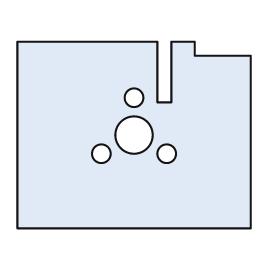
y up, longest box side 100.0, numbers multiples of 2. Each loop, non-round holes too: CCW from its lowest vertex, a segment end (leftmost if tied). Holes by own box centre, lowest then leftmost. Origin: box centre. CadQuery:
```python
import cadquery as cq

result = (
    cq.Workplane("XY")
    .moveTo(-50.0, -40.0)
    .lineTo(50.0, -40.0)
    .lineTo(50.0, 34.0)
    .lineTo(26.0, 34.0)
    .lineTo(26.0, 40.0)
    .lineTo(16.0, 40.0)
    .lineTo(16.0, 14.0)
    .lineTo(10.0, 14.0)
    .lineTo(10.0, 40.0)
    .lineTo(-50.0, 40.0)
    .close()
    .moveTo(-14.0, -8.0)
    .circle(4.0)
    .moveTo(14.0, -8.0)
    .circle(4.0)
    .moveTo(0.0, 0.0)
    .circle(8.0)
    .moveTo(0.0, 16.0)
    .circle(4.0)
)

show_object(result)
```